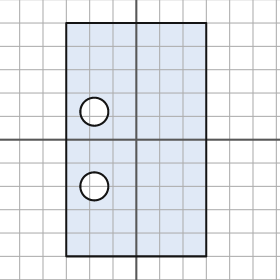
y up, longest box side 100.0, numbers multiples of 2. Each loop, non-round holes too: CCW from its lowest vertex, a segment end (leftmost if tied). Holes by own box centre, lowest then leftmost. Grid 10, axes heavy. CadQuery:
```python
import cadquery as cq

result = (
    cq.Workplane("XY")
    .moveTo(-30.0, -50.0)
    .lineTo(30.0, -50.0)
    .lineTo(30.0, 50.0)
    .lineTo(-30.0, 50.0)
    .close()
    .moveTo(-18.0, -20.0)
    .circle(6.0)
    .moveTo(-18.0, 12.0)
    .circle(6.0)
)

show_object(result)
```